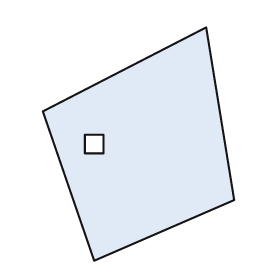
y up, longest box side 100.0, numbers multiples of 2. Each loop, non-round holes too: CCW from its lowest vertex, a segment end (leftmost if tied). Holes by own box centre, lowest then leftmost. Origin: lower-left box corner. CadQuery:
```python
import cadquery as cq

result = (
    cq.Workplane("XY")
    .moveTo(22.0, 0.0)
    .lineTo(82.0, 26.0)
    .lineTo(70.0, 100.0)
    .lineTo(0.0, 64.0)
    .close()
    .moveTo(18.0, 46.0)
    .lineTo(26.0, 46.0)
    .lineTo(26.0, 54.0)
    .lineTo(18.0, 54.0)
    .close()
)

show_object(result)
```